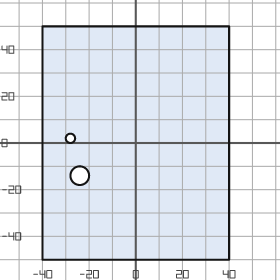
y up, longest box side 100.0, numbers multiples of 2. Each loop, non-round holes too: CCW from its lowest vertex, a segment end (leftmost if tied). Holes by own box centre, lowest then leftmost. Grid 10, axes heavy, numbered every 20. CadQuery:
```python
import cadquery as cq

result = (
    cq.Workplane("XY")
    .moveTo(-40.0, -50.0)
    .lineTo(40.0, -50.0)
    .lineTo(40.0, 50.0)
    .lineTo(-40.0, 50.0)
    .close()
    .moveTo(-24.0, -14.0)
    .circle(4.0)
    .moveTo(-28.0, 2.0)
    .circle(2.0)
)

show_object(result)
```